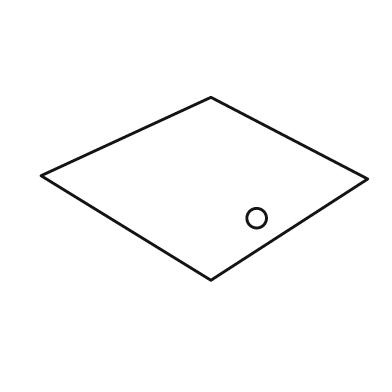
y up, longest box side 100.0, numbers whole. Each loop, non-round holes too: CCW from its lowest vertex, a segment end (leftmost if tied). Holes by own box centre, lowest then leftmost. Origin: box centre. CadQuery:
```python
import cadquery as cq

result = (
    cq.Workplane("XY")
    .moveTo(2.0, -28.0)
    .lineTo(50.0, 3.0)
    .lineTo(2.0, 28.0)
    .lineTo(-50.0, 4.0)
    .close()
    .moveTo(16.0, -9.0)
    .circle(3.0)
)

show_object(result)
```